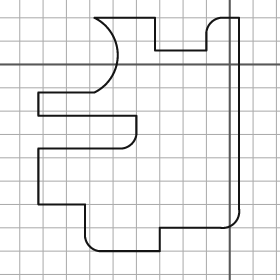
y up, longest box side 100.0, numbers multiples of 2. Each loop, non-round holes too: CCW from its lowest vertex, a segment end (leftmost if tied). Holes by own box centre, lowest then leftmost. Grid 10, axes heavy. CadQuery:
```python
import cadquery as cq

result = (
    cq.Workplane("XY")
    .moveTo(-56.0, -80.0)
    .lineTo(-30.0, -80.0)
    .lineTo(-30.0, -70.0)
    .lineTo(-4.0, -70.0)
    .threePointArc((2.0, -68.0), (4.0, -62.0))
    .lineTo(4.0, 20.0)
    .lineTo(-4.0, 20.0)
    .threePointArc((-8.0, 18.0), (-10.0, 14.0))
    .lineTo(-10.0, 6.0)
    .lineTo(-32.0, 6.0)
    .lineTo(-32.0, 20.0)
    .lineTo(-58.0, 20.0)
    .threePointArc((-48.0, 4.0), (-58.0, -12.0))
    .lineTo(-82.0, -12.0)
    .lineTo(-82.0, -22.0)
    .lineTo(-40.0, -22.0)
    .lineTo(-40.0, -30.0)
    .threePointArc((-42.0, -34.0), (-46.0, -36.0))
    .lineTo(-82.0, -36.0)
    .lineTo(-82.0, -60.0)
    .lineTo(-62.0, -60.0)
    .lineTo(-62.0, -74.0)
    .threePointArc((-60.0, -78.0), (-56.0, -80.0))
    .close()
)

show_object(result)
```